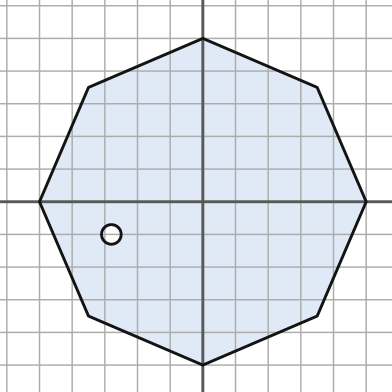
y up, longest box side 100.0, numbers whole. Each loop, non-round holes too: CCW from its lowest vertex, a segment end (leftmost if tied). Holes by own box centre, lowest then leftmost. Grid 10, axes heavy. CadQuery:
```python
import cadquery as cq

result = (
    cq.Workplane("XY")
    .moveTo(0.0, -50.0)
    .lineTo(35.0, -35.0)
    .lineTo(50.0, 0.0)
    .lineTo(35.0, 35.0)
    .lineTo(0.0, 50.0)
    .lineTo(-35.0, 35.0)
    .lineTo(-50.0, 0.0)
    .lineTo(-35.0, -35.0)
    .close()
    .moveTo(-28.0, -10.0)
    .circle(3.0)
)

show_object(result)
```